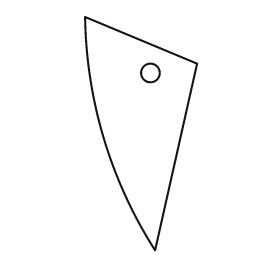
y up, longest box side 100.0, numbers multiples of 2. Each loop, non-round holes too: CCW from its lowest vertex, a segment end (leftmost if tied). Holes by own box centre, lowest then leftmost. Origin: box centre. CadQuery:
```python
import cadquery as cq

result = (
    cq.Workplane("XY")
    .moveTo(6.0, -50.0)
    .lineTo(24.0, 30.0)
    .lineTo(-24.0, 50.0)
    .threePointArc((-16.0, -2.0), (6.0, -50.0))
    .close()
    .moveTo(4.0, 26.0)
    .circle(4.0)
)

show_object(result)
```